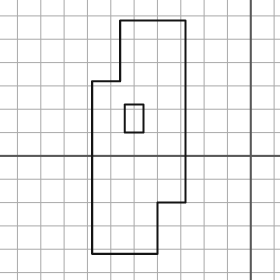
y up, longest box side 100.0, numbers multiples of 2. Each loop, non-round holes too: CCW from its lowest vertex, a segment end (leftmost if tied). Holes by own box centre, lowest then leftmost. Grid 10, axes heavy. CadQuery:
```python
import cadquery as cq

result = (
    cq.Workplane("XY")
    .moveTo(-68.0, -42.0)
    .lineTo(-40.0, -42.0)
    .lineTo(-40.0, -20.0)
    .lineTo(-28.0, -20.0)
    .lineTo(-28.0, 58.0)
    .lineTo(-56.0, 58.0)
    .lineTo(-56.0, 32.0)
    .lineTo(-68.0, 32.0)
    .close()
    .moveTo(-54.0, 10.0)
    .lineTo(-46.0, 10.0)
    .lineTo(-46.0, 22.0)
    .lineTo(-54.0, 22.0)
    .close()
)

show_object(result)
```